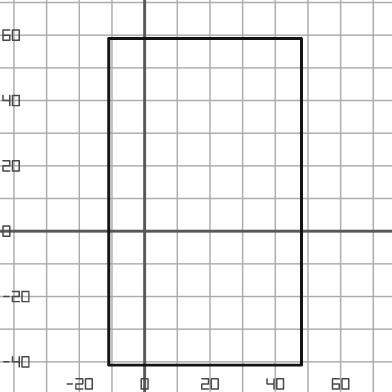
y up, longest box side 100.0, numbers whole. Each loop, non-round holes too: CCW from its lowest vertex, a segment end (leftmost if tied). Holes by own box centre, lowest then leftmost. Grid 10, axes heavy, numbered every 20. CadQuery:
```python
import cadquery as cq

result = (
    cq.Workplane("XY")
    .moveTo(-11.0, -41.0)
    .lineTo(48.0, -41.0)
    .lineTo(48.0, 59.0)
    .lineTo(-11.0, 59.0)
    .close()
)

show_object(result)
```